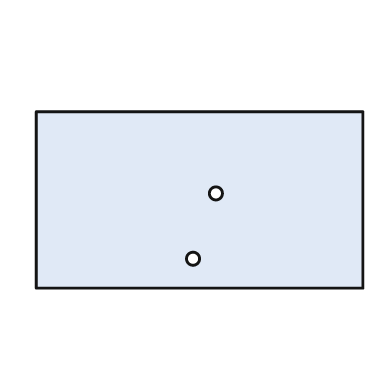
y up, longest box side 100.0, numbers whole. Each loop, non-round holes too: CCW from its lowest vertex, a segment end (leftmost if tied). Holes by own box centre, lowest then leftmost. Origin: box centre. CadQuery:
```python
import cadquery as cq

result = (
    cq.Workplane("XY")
    .moveTo(-50.0, -27.0)
    .lineTo(50.0, -27.0)
    .lineTo(50.0, 27.0)
    .lineTo(-50.0, 27.0)
    .close()
    .moveTo(-2.0, -18.0)
    .circle(2.0)
    .moveTo(5.0, 2.0)
    .circle(2.0)
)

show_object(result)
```